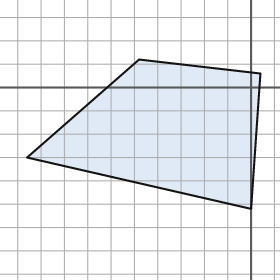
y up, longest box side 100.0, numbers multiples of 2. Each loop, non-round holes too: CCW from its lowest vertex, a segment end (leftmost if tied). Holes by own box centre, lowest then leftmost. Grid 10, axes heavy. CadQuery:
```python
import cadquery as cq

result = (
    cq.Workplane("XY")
    .moveTo(0.0, -52.0)
    .lineTo(4.0, 6.0)
    .lineTo(-48.0, 12.0)
    .lineTo(-96.0, -30.0)
    .close()
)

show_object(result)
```